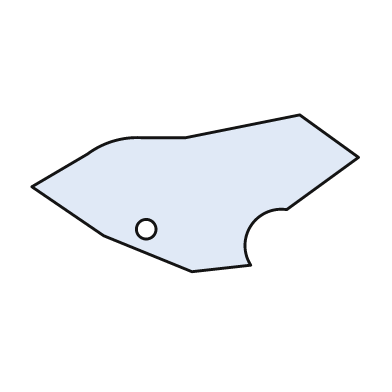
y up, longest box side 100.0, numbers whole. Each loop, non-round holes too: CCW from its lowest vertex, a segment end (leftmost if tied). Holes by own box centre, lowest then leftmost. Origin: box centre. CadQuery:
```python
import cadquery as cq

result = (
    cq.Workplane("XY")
    .moveTo(-1.0, -24.0)
    .lineTo(17.0, -22.0)
    .threePointArc((17.0, -10.0), (28.0, -5.0))
    .lineTo(50.0, 11.0)
    .lineTo(32.0, 24.0)
    .lineTo(-3.0, 17.0)
    .lineTo(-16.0, 17.0)
    .threePointArc((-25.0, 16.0), (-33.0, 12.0))
    .lineTo(-50.0, 2.0)
    .lineTo(-28.0, -13.0)
    .close()
    .moveTo(-15.0, -11.0)
    .circle(3.0)
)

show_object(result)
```